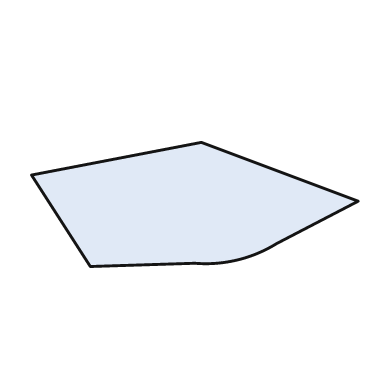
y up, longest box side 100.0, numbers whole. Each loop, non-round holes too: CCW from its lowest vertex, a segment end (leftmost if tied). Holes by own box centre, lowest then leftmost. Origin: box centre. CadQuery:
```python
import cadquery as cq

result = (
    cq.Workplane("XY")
    .moveTo(-32.0, -19.0)
    .lineTo(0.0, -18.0)
    .threePointArc((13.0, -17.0), (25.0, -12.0))
    .lineTo(50.0, 1.0)
    .lineTo(2.0, 19.0)
    .lineTo(-50.0, 9.0)
    .close()
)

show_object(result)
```